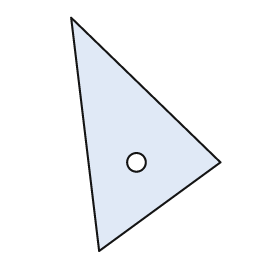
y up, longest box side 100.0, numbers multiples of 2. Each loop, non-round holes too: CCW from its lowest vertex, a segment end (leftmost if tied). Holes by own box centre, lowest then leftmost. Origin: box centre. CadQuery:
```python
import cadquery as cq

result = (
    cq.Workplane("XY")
    .moveTo(-20.0, -50.0)
    .lineTo(32.0, -12.0)
    .lineTo(-32.0, 50.0)
    .close()
    .moveTo(-4.0, -12.0)
    .circle(4.0)
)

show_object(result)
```